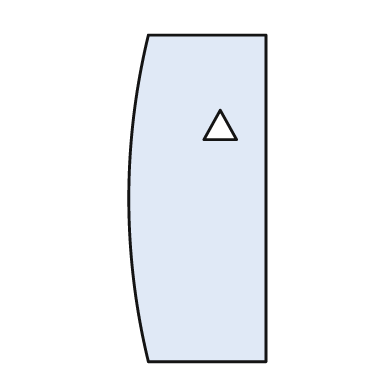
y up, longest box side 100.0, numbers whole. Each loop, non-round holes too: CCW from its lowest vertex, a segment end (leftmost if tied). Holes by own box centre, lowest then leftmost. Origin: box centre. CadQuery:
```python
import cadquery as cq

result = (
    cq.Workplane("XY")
    .moveTo(-15.0, -50.0)
    .lineTo(21.0, -50.0)
    .lineTo(21.0, 50.0)
    .lineTo(-15.0, 50.0)
    .threePointArc((-21.0, 0.0), (-15.0, -50.0))
    .close()
    .moveTo(2.0, 18.0)
    .lineTo(12.0, 18.0)
    .lineTo(7.0, 27.0)
    .close()
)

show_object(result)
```